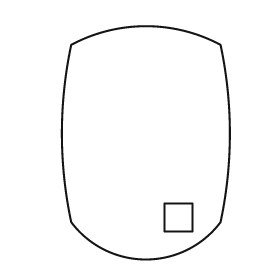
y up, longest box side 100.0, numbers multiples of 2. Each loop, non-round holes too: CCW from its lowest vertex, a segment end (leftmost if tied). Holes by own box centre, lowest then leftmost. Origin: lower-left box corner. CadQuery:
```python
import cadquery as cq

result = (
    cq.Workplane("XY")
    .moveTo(4.0, 16.0)
    .threePointArc((36.0, 0.0), (68.0, 16.0))
    .threePointArc((72.0, 54.0), (68.0, 92.0))
    .threePointArc((36.0, 100.0), (4.0, 92.0))
    .threePointArc((0.0, 54.0), (4.0, 16.0))
    .close()
    .moveTo(44.0, 12.0)
    .lineTo(56.0, 12.0)
    .lineTo(56.0, 24.0)
    .lineTo(44.0, 24.0)
    .close()
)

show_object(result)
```